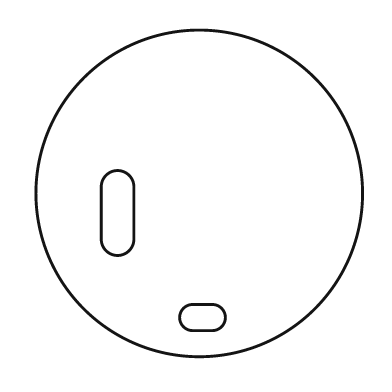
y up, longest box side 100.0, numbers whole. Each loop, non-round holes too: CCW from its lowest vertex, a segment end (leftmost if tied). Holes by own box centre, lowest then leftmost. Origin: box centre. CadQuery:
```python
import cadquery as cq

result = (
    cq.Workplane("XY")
    .moveTo(0.0, 0.0)
    .circle(50.0)
    .moveTo(-2.0, -42.0)
    .lineTo(4.0, -42.0)
    .threePointArc((8.0, -38.0), (4.0, -34.0))
    .lineTo(-2.0, -34.0)
    .threePointArc((-6.0, -38.0), (-2.0, -42.0))
    .close()
    .moveTo(-30.0, -14.0)
    .threePointArc((-25.0, -19.0), (-20.0, -14.0))
    .lineTo(-20.0, 2.0)
    .threePointArc((-25.0, 7.0), (-30.0, 2.0))
    .close()
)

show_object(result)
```